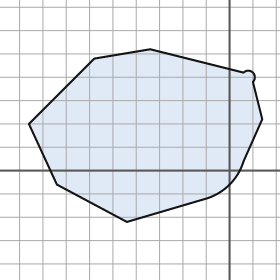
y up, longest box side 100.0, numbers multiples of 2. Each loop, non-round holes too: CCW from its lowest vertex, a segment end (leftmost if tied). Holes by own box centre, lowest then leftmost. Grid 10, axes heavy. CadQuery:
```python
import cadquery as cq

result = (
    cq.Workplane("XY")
    .moveTo(-44.0, -22.0)
    .lineTo(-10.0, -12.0)
    .threePointArc((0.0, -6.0), (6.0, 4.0))
    .lineTo(14.0, 22.0)
    .lineTo(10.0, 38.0)
    .threePointArc((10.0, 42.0), (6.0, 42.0))
    .lineTo(-34.0, 52.0)
    .lineTo(-58.0, 48.0)
    .lineTo(-86.0, 20.0)
    .lineTo(-74.0, -6.0)
    .close()
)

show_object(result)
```